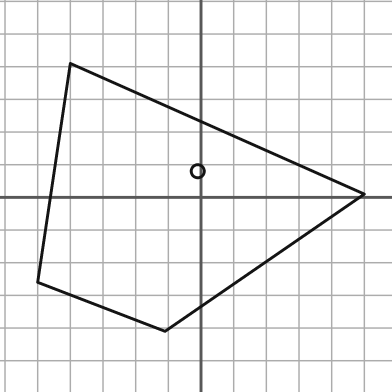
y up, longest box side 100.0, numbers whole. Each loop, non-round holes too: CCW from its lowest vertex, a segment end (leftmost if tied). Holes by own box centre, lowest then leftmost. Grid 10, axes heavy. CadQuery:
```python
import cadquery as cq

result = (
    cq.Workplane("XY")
    .moveTo(-11.0, -41.0)
    .lineTo(50.0, 1.0)
    .lineTo(-40.0, 41.0)
    .lineTo(-50.0, -26.0)
    .close()
    .moveTo(-1.0, 8.0)
    .circle(2.0)
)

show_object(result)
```